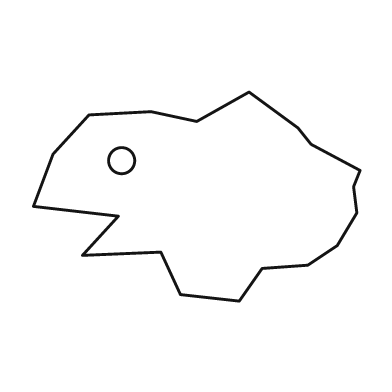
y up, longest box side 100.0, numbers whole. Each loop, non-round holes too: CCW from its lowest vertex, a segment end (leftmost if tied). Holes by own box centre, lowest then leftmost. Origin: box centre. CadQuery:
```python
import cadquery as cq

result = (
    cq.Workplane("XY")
    .moveTo(13.0, -32.0)
    .lineTo(20.0, -22.0)
    .lineTo(34.0, -21.0)
    .lineTo(43.0, -15.0)
    .lineTo(49.0, -5.0)
    .lineTo(48.0, 3.0)
    .lineTo(50.0, 8.0)
    .lineTo(35.0, 16.0)
    .lineTo(31.0, 21.0)
    .lineTo(16.0, 32.0)
    .lineTo(0.0, 23.0)
    .lineTo(-14.0, 26.0)
    .lineTo(-33.0, 25.0)
    .lineTo(-44.0, 13.0)
    .lineTo(-50.0, -3.0)
    .lineTo(-24.0, -6.0)
    .lineTo(-35.0, -18.0)
    .lineTo(-11.0, -17.0)
    .lineTo(-5.0, -30.0)
    .close()
    .moveTo(-23.0, 11.0)
    .circle(4.0)
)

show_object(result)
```